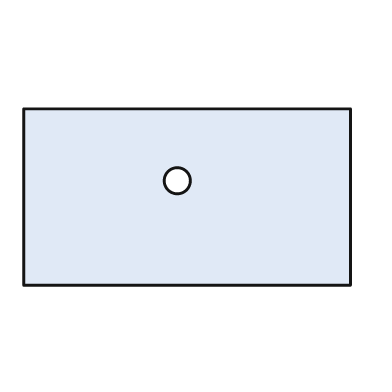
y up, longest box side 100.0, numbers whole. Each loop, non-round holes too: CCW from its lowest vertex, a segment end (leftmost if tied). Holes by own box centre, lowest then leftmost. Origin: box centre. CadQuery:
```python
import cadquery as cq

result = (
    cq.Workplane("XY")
    .moveTo(-50.0, -27.0)
    .lineTo(50.0, -27.0)
    .lineTo(50.0, 27.0)
    .lineTo(-50.0, 27.0)
    .close()
    .moveTo(-3.0, 5.0)
    .circle(4.0)
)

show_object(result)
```